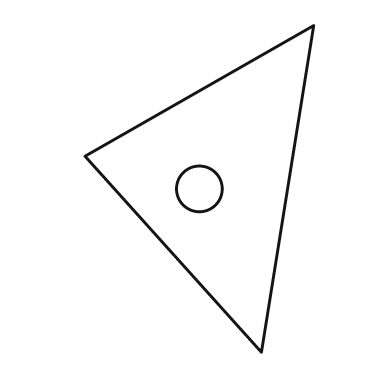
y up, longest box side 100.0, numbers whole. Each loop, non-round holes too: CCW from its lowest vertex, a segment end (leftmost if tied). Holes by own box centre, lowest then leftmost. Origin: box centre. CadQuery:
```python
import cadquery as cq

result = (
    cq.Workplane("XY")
    .moveTo(19.0, -50.0)
    .lineTo(35.0, 50.0)
    .lineTo(-35.0, 10.0)
    .close()
    .moveTo(0.0, 0.0)
    .circle(7.0)
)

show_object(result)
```